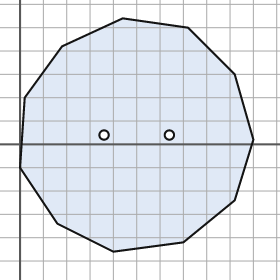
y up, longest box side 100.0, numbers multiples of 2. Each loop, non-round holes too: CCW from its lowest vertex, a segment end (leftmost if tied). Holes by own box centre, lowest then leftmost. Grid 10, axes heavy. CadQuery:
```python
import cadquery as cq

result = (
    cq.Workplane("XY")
    .moveTo(40.0, -46.0)
    .lineTo(70.0, -42.0)
    .lineTo(92.0, -24.0)
    .lineTo(100.0, 2.0)
    .lineTo(92.0, 30.0)
    .lineTo(72.0, 50.0)
    .lineTo(44.0, 54.0)
    .lineTo(18.0, 42.0)
    .lineTo(2.0, 20.0)
    .lineTo(0.0, -10.0)
    .lineTo(16.0, -34.0)
    .close()
    .moveTo(36.0, 4.0)
    .circle(2.0)
    .moveTo(64.0, 4.0)
    .circle(2.0)
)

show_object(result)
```